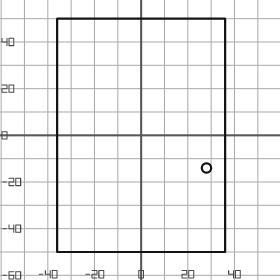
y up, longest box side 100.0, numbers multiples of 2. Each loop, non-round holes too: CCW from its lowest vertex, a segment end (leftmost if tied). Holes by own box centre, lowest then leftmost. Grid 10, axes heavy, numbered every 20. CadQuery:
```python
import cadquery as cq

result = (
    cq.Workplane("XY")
    .moveTo(-36.0, -50.0)
    .lineTo(36.0, -50.0)
    .lineTo(36.0, 50.0)
    .lineTo(-36.0, 50.0)
    .close()
    .moveTo(28.0, -14.0)
    .circle(2.0)
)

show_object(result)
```